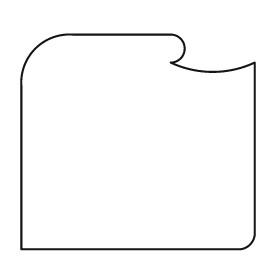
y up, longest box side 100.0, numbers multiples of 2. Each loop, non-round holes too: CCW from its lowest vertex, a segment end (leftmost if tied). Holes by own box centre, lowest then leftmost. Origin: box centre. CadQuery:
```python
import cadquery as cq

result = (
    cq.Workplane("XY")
    .moveTo(-50.0, -46.0)
    .lineTo(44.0, -46.0)
    .threePointArc((48.0, -44.0), (50.0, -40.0))
    .lineTo(50.0, 34.0)
    .threePointArc((32.0, 30.0), (14.0, 34.0))
    .threePointArc((20.0, 40.0), (14.0, 46.0))
    .lineTo(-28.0, 46.0)
    .threePointArc((-44.0, 40.0), (-50.0, 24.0))
    .close()
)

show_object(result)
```